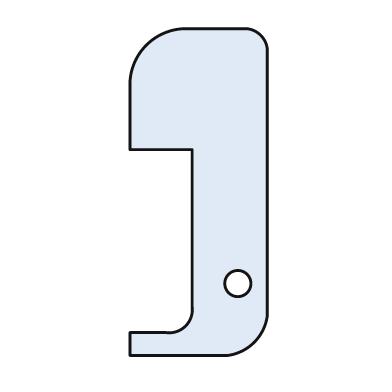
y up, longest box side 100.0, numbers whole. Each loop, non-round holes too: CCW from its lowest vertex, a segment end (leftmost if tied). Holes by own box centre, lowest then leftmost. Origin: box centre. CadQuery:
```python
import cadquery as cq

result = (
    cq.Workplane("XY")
    .moveTo(-21.0, -50.0)
    .lineTo(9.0, -50.0)
    .threePointArc((17.0, -46.0), (21.0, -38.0))
    .lineTo(21.0, 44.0)
    .threePointArc((19.0, 48.0), (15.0, 50.0))
    .lineTo(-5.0, 50.0)
    .threePointArc((-16.0, 45.0), (-21.0, 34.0))
    .lineTo(-21.0, 13.0)
    .lineTo(-2.0, 13.0)
    .lineTo(-2.0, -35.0)
    .threePointArc((-4.0, -41.0), (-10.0, -43.0))
    .lineTo(-21.0, -43.0)
    .close()
    .moveTo(12.0, -28.0)
    .circle(4.0)
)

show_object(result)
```